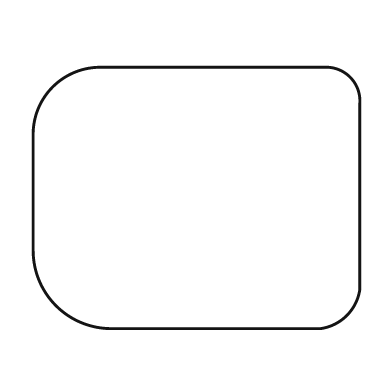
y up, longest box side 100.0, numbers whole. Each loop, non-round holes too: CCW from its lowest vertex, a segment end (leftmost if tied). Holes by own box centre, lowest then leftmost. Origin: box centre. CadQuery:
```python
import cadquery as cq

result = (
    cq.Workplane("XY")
    .moveTo(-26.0, -40.0)
    .lineTo(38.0, -40.0)
    .threePointArc((46.0, -36.0), (50.0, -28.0))
    .lineTo(50.0, 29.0)
    .threePointArc((47.0, 37.0), (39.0, 40.0))
    .lineTo(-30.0, 40.0)
    .threePointArc((-44.0, 34.0), (-50.0, 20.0))
    .lineTo(-50.0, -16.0)
    .threePointArc((-43.0, -33.0), (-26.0, -40.0))
    .close()
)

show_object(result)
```